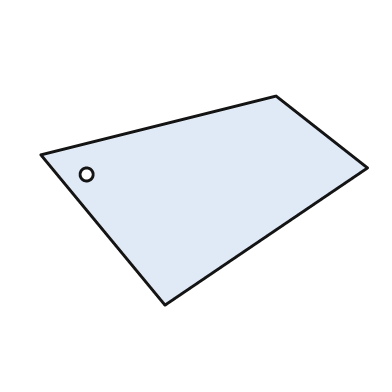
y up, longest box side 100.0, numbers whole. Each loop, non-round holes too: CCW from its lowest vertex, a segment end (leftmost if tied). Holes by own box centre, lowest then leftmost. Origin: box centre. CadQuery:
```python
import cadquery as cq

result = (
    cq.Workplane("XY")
    .moveTo(-12.0, -32.0)
    .lineTo(50.0, 10.0)
    .lineTo(22.0, 32.0)
    .lineTo(-50.0, 14.0)
    .close()
    .moveTo(-36.0, 8.0)
    .circle(2.0)
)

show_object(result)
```